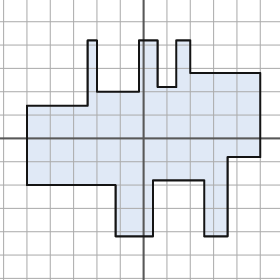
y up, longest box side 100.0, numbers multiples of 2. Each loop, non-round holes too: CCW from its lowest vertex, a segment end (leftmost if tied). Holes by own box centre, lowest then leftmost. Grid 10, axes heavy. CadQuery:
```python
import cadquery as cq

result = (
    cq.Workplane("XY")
    .moveTo(-12.0, -42.0)
    .lineTo(4.0, -42.0)
    .lineTo(4.0, -18.0)
    .lineTo(26.0, -18.0)
    .lineTo(26.0, -42.0)
    .lineTo(36.0, -42.0)
    .lineTo(36.0, -8.0)
    .lineTo(50.0, -8.0)
    .lineTo(50.0, 28.0)
    .lineTo(20.0, 28.0)
    .lineTo(20.0, 42.0)
    .lineTo(14.0, 42.0)
    .lineTo(14.0, 22.0)
    .lineTo(6.0, 22.0)
    .lineTo(6.0, 42.0)
    .lineTo(-2.0, 42.0)
    .lineTo(-2.0, 20.0)
    .lineTo(-20.0, 20.0)
    .lineTo(-20.0, 42.0)
    .lineTo(-24.0, 42.0)
    .lineTo(-24.0, 14.0)
    .lineTo(-50.0, 14.0)
    .lineTo(-50.0, -20.0)
    .lineTo(-12.0, -20.0)
    .close()
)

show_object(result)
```